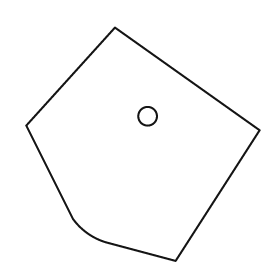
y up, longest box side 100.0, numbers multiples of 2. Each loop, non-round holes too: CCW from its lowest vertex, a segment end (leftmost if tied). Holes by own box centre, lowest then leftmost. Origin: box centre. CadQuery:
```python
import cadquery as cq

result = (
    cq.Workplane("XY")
    .moveTo(14.0, -50.0)
    .lineTo(50.0, 6.0)
    .lineTo(-12.0, 50.0)
    .lineTo(-50.0, 8.0)
    .lineTo(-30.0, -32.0)
    .threePointArc((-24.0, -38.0), (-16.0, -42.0))
    .close()
    .moveTo(2.0, 12.0)
    .circle(4.0)
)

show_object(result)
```